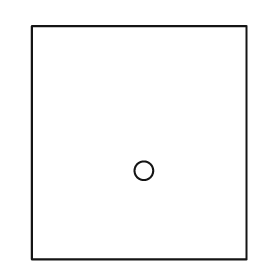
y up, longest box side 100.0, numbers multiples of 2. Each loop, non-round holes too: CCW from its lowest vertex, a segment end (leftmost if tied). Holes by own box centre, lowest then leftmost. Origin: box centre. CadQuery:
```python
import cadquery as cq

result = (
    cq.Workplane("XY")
    .moveTo(-46.0, -50.0)
    .lineTo(46.0, -50.0)
    .lineTo(46.0, 50.0)
    .lineTo(-46.0, 50.0)
    .close()
    .moveTo(2.0, -12.0)
    .circle(4.0)
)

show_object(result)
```